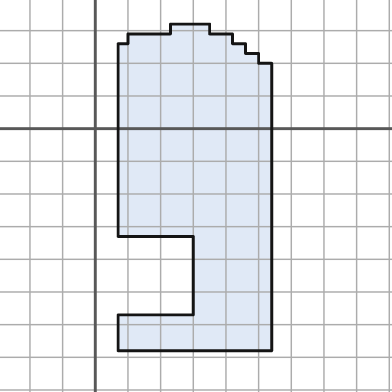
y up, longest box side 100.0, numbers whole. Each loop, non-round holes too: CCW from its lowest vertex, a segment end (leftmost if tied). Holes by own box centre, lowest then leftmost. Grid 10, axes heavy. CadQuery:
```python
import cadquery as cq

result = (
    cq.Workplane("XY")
    .moveTo(7.0, -68.0)
    .lineTo(54.0, -68.0)
    .lineTo(54.0, 20.0)
    .lineTo(50.0, 20.0)
    .lineTo(50.0, 23.0)
    .lineTo(46.0, 23.0)
    .lineTo(46.0, 26.0)
    .lineTo(42.0, 26.0)
    .lineTo(42.0, 29.0)
    .lineTo(35.0, 29.0)
    .lineTo(35.0, 32.0)
    .lineTo(23.0, 32.0)
    .lineTo(23.0, 29.0)
    .lineTo(10.0, 29.0)
    .lineTo(10.0, 26.0)
    .lineTo(7.0, 26.0)
    .lineTo(7.0, -33.0)
    .lineTo(30.0, -33.0)
    .lineTo(30.0, -57.0)
    .lineTo(7.0, -57.0)
    .close()
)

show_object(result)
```